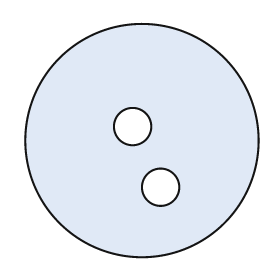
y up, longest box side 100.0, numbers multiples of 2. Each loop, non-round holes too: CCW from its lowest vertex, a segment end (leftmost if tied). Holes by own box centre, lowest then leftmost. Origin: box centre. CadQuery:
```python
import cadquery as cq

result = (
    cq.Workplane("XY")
    .moveTo(0.0, 0.0)
    .circle(50.0)
    .moveTo(8.0, -20.0)
    .circle(8.0)
    .moveTo(-4.0, 6.0)
    .circle(8.0)
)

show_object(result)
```